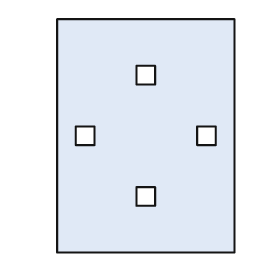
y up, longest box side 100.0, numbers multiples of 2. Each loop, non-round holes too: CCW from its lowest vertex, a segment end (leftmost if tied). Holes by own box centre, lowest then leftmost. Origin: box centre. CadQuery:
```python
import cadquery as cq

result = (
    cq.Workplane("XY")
    .moveTo(-38.0, -50.0)
    .lineTo(38.0, -50.0)
    .lineTo(38.0, 50.0)
    .lineTo(-38.0, 50.0)
    .close()
    .moveTo(-4.0, -30.0)
    .lineTo(4.0, -30.0)
    .lineTo(4.0, -22.0)
    .lineTo(-4.0, -22.0)
    .close()
    .moveTo(-30.0, -4.0)
    .lineTo(-22.0, -4.0)
    .lineTo(-22.0, 4.0)
    .lineTo(-30.0, 4.0)
    .close()
    .moveTo(22.0, -4.0)
    .lineTo(30.0, -4.0)
    .lineTo(30.0, 4.0)
    .lineTo(22.0, 4.0)
    .close()
    .moveTo(-4.0, 22.0)
    .lineTo(4.0, 22.0)
    .lineTo(4.0, 30.0)
    .lineTo(-4.0, 30.0)
    .close()
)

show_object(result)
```